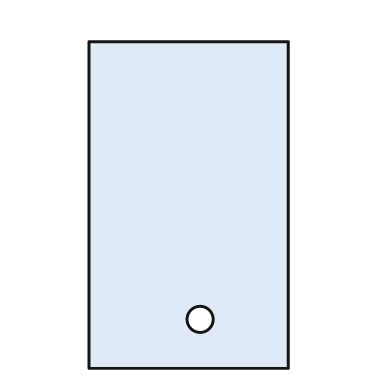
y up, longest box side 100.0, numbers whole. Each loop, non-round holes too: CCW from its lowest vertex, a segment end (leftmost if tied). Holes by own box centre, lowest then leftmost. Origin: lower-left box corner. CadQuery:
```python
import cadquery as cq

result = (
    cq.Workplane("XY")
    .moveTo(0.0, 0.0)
    .lineTo(61.0, 0.0)
    .lineTo(61.0, 100.0)
    .lineTo(0.0, 100.0)
    .close()
    .moveTo(34.0, 15.0)
    .circle(4.0)
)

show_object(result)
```